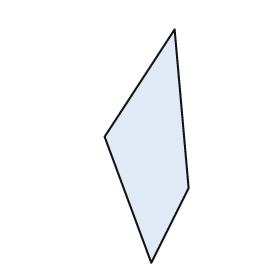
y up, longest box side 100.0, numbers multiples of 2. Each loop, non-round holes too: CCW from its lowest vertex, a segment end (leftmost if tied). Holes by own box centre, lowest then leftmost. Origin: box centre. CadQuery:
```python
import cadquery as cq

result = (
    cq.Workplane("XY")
    .moveTo(2.0, -50.0)
    .lineTo(18.0, -18.0)
    .lineTo(12.0, 50.0)
    .lineTo(-18.0, 4.0)
    .close()
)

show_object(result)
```